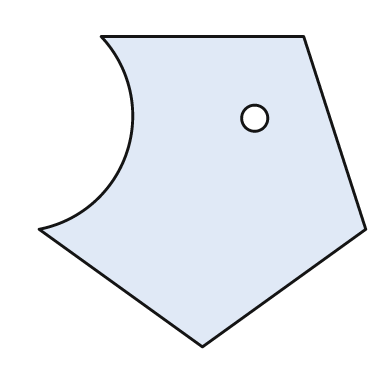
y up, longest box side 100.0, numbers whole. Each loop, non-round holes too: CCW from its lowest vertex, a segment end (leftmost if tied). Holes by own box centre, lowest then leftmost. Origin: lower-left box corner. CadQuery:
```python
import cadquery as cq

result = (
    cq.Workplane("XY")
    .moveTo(50.0, 0.0)
    .lineTo(100.0, 36.0)
    .lineTo(81.0, 95.0)
    .lineTo(19.0, 95.0)
    .threePointArc((27.0, 60.0), (0.0, 36.0))
    .close()
    .moveTo(66.0, 70.0)
    .circle(4.0)
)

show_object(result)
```